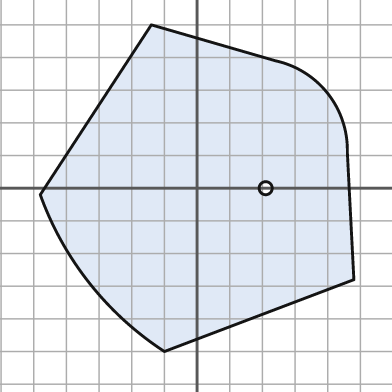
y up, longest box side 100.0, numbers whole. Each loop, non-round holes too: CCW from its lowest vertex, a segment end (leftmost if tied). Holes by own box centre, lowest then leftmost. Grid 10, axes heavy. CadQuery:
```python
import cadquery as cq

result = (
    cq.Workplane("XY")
    .moveTo(-10.0, -50.0)
    .lineTo(48.0, -28.0)
    .lineTo(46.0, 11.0)
    .threePointArc((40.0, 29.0), (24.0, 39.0))
    .lineTo(-14.0, 50.0)
    .lineTo(-48.0, -2.0)
    .threePointArc((-33.0, -29.0), (-10.0, -50.0))
    .close()
    .moveTo(21.0, 0.0)
    .circle(2.0)
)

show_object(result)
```